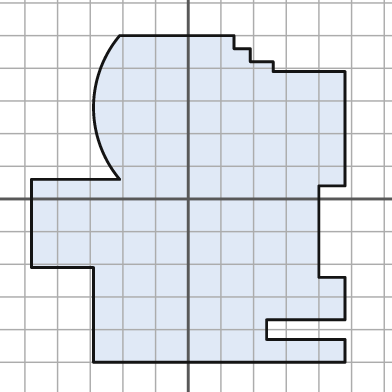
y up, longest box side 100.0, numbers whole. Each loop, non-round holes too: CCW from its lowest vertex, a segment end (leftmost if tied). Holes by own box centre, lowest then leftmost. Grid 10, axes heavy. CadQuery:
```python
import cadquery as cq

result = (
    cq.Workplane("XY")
    .moveTo(-29.0, -50.0)
    .lineTo(48.0, -50.0)
    .lineTo(48.0, -43.0)
    .lineTo(24.0, -43.0)
    .lineTo(24.0, -37.0)
    .lineTo(48.0, -37.0)
    .lineTo(48.0, -24.0)
    .lineTo(40.0, -24.0)
    .lineTo(40.0, 4.0)
    .lineTo(48.0, 4.0)
    .lineTo(48.0, 39.0)
    .lineTo(26.0, 39.0)
    .lineTo(26.0, 42.0)
    .lineTo(19.0, 42.0)
    .lineTo(19.0, 46.0)
    .lineTo(14.0, 46.0)
    .lineTo(14.0, 50.0)
    .lineTo(-21.0, 50.0)
    .threePointArc((-29.0, 28.0), (-21.0, 6.0))
    .lineTo(-48.0, 6.0)
    .lineTo(-48.0, -21.0)
    .lineTo(-29.0, -21.0)
    .close()
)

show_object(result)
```